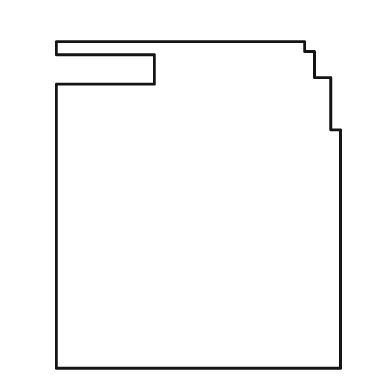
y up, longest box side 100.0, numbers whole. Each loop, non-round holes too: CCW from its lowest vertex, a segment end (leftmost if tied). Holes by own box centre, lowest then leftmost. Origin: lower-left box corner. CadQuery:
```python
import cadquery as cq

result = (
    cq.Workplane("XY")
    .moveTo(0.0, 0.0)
    .lineTo(87.0, 0.0)
    .lineTo(87.0, 73.0)
    .lineTo(84.0, 73.0)
    .lineTo(84.0, 89.0)
    .lineTo(79.0, 89.0)
    .lineTo(79.0, 97.0)
    .lineTo(76.0, 97.0)
    .lineTo(76.0, 100.0)
    .lineTo(0.0, 100.0)
    .lineTo(0.0, 96.0)
    .lineTo(30.0, 96.0)
    .lineTo(30.0, 87.0)
    .lineTo(0.0, 87.0)
    .close()
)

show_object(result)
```